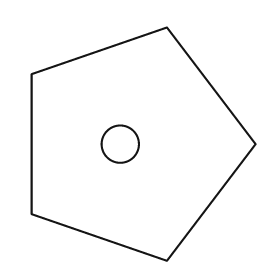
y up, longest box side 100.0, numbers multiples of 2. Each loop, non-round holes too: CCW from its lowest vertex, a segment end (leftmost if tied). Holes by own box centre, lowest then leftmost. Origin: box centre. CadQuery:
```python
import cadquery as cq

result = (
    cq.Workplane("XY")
    .moveTo(10.0, -50.0)
    .lineTo(48.0, 0.0)
    .lineTo(10.0, 50.0)
    .lineTo(-48.0, 30.0)
    .lineTo(-48.0, -30.0)
    .close()
    .moveTo(-10.0, 0.0)
    .circle(8.0)
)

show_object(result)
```